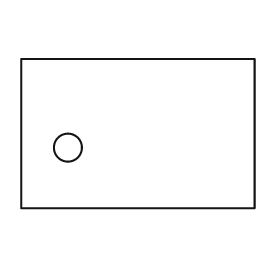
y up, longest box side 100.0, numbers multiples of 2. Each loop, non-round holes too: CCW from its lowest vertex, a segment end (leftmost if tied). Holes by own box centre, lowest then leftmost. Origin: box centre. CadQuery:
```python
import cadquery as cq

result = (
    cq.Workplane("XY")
    .moveTo(-50.0, -32.0)
    .lineTo(50.0, -32.0)
    .lineTo(50.0, 32.0)
    .lineTo(-50.0, 32.0)
    .close()
    .moveTo(-30.0, -6.0)
    .circle(6.0)
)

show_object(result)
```